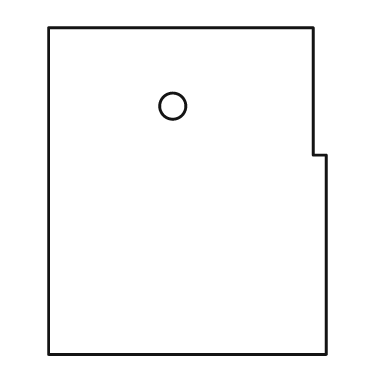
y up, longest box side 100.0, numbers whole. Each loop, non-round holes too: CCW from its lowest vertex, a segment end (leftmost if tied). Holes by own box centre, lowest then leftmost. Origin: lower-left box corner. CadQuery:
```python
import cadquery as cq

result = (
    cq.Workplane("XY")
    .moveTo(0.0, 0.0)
    .lineTo(85.0, 0.0)
    .lineTo(85.0, 61.0)
    .lineTo(81.0, 61.0)
    .lineTo(81.0, 100.0)
    .lineTo(0.0, 100.0)
    .close()
    .moveTo(38.0, 76.0)
    .circle(4.0)
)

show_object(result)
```